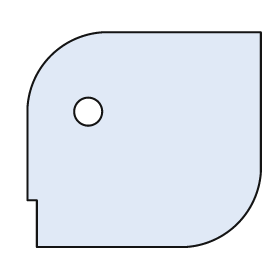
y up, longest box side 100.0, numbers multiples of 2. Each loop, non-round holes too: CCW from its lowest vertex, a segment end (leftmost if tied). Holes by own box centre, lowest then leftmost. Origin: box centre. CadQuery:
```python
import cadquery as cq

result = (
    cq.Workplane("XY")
    .moveTo(-46.0, -46.0)
    .lineTo(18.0, -46.0)
    .threePointArc((40.0, -36.0), (50.0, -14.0))
    .lineTo(50.0, 46.0)
    .lineTo(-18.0, 46.0)
    .threePointArc((-40.0, 36.0), (-50.0, 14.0))
    .lineTo(-50.0, -26.0)
    .lineTo(-46.0, -26.0)
    .close()
    .moveTo(-24.0, 12.0)
    .circle(6.0)
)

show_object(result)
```